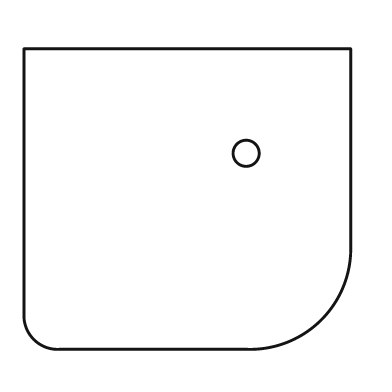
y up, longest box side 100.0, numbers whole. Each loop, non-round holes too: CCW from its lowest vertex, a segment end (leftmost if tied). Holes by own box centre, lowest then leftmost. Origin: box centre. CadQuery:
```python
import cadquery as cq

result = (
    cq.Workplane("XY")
    .moveTo(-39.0, -46.0)
    .lineTo(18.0, -46.0)
    .threePointArc((41.0, -37.0), (50.0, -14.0))
    .lineTo(50.0, 46.0)
    .lineTo(-50.0, 46.0)
    .lineTo(-50.0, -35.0)
    .threePointArc((-47.0, -43.0), (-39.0, -46.0))
    .close()
    .moveTo(18.0, 14.0)
    .circle(4.0)
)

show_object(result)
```